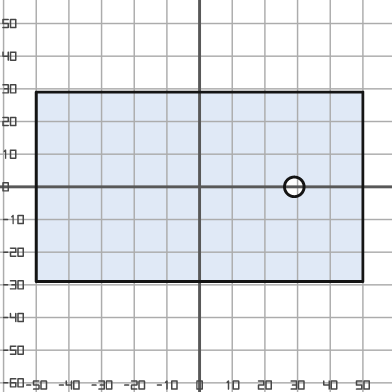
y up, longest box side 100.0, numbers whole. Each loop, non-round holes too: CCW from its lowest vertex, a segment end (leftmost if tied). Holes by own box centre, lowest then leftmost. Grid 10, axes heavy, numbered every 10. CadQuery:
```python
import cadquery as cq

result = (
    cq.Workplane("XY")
    .moveTo(-50.0, -29.0)
    .lineTo(50.0, -29.0)
    .lineTo(50.0, 29.0)
    .lineTo(-50.0, 29.0)
    .close()
    .moveTo(29.0, 0.0)
    .circle(3.0)
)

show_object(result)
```